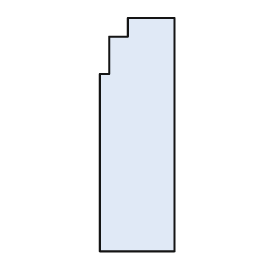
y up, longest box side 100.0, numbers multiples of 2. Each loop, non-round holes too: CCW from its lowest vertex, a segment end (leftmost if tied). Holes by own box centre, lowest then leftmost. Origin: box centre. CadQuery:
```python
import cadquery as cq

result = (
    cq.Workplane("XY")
    .moveTo(-16.0, -50.0)
    .lineTo(16.0, -50.0)
    .lineTo(16.0, 50.0)
    .lineTo(-4.0, 50.0)
    .lineTo(-4.0, 42.0)
    .lineTo(-12.0, 42.0)
    .lineTo(-12.0, 26.0)
    .lineTo(-16.0, 26.0)
    .close()
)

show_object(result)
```